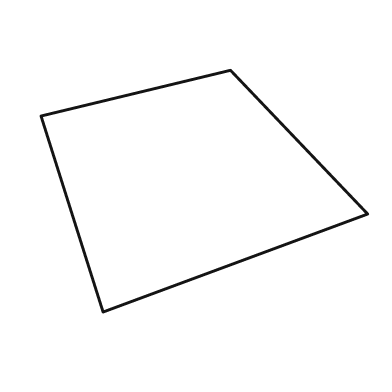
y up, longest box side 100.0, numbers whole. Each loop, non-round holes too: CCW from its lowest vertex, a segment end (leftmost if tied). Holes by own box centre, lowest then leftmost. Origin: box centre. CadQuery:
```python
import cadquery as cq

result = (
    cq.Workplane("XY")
    .moveTo(-31.0, -37.0)
    .lineTo(50.0, -7.0)
    .lineTo(8.0, 37.0)
    .lineTo(-50.0, 23.0)
    .close()
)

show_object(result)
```